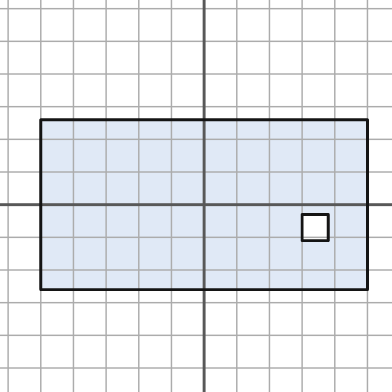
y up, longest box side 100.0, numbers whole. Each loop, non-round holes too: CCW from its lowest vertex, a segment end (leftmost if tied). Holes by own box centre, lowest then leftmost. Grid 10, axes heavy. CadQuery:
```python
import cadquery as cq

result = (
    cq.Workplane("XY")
    .moveTo(-50.0, -26.0)
    .lineTo(50.0, -26.0)
    .lineTo(50.0, 26.0)
    .lineTo(-50.0, 26.0)
    .close()
    .moveTo(30.0, -11.0)
    .lineTo(38.0, -11.0)
    .lineTo(38.0, -3.0)
    .lineTo(30.0, -3.0)
    .close()
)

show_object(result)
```